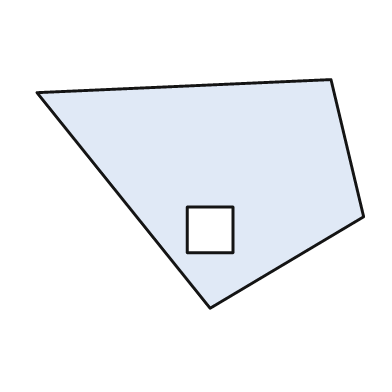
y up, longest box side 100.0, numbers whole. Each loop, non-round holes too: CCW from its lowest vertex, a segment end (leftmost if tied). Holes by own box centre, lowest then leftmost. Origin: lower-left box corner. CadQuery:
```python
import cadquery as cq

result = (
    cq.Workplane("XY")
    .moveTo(53.0, 0.0)
    .lineTo(100.0, 28.0)
    .lineTo(90.0, 70.0)
    .lineTo(0.0, 66.0)
    .close()
    .moveTo(46.0, 17.0)
    .lineTo(60.0, 17.0)
    .lineTo(60.0, 31.0)
    .lineTo(46.0, 31.0)
    .close()
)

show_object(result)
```